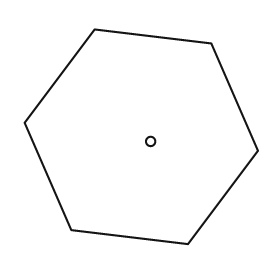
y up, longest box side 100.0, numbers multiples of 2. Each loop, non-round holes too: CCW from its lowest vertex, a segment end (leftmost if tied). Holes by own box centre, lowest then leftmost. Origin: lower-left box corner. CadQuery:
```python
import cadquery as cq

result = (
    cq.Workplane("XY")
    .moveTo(70.0, 0.0)
    .lineTo(100.0, 40.0)
    .lineTo(80.0, 86.0)
    .lineTo(30.0, 92.0)
    .lineTo(0.0, 52.0)
    .lineTo(20.0, 6.0)
    .close()
    .moveTo(54.0, 44.0)
    .circle(2.0)
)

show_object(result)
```